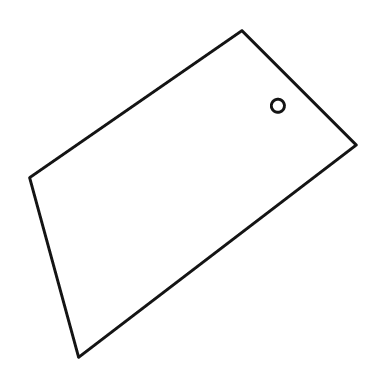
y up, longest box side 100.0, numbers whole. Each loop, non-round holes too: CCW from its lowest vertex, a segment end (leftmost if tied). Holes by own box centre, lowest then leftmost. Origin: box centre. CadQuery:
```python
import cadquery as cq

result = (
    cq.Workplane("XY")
    .moveTo(-35.0, -50.0)
    .lineTo(50.0, 15.0)
    .lineTo(15.0, 50.0)
    .lineTo(-50.0, 5.0)
    .close()
    .moveTo(26.0, 27.0)
    .circle(2.0)
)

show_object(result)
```